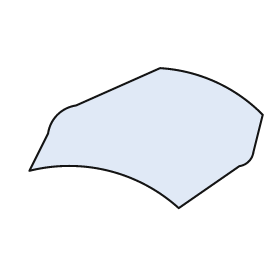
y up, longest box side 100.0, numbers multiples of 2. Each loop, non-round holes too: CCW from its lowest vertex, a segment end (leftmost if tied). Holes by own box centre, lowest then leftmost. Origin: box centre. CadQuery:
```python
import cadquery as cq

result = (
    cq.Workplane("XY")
    .moveTo(14.0, -30.0)
    .lineTo(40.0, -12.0)
    .threePointArc((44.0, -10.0), (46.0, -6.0))
    .lineTo(50.0, 10.0)
    .threePointArc((30.0, 24.0), (6.0, 30.0))
    .lineTo(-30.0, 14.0)
    .threePointArc((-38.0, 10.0), (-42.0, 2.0))
    .lineTo(-50.0, -14.0)
    .threePointArc((-16.0, -14.0), (14.0, -30.0))
    .close()
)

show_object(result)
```